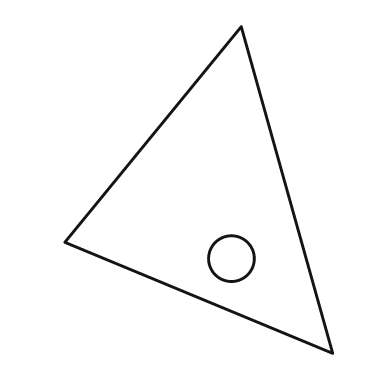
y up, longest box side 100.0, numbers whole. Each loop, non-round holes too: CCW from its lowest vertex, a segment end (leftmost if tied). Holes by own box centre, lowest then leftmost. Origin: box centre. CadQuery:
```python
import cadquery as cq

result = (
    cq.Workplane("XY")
    .moveTo(41.0, -50.0)
    .lineTo(13.0, 50.0)
    .lineTo(-41.0, -16.0)
    .close()
    .moveTo(10.0, -21.0)
    .circle(7.0)
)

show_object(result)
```